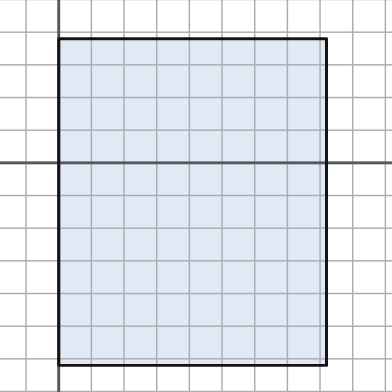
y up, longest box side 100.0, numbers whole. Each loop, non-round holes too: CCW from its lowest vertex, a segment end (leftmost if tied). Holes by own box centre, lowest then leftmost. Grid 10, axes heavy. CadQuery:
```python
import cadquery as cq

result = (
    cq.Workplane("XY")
    .moveTo(0.0, -62.0)
    .lineTo(82.0, -62.0)
    .lineTo(82.0, 38.0)
    .lineTo(0.0, 38.0)
    .close()
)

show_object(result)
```